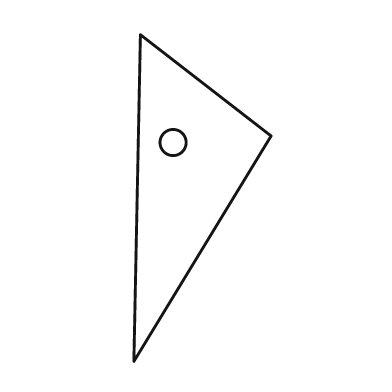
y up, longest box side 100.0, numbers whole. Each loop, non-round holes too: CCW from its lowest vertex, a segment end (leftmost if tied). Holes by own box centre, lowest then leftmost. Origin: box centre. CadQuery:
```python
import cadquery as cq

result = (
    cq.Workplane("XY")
    .moveTo(-21.0, -50.0)
    .lineTo(21.0, 19.0)
    .lineTo(-19.0, 50.0)
    .close()
    .moveTo(-9.0, 17.0)
    .circle(4.0)
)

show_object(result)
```